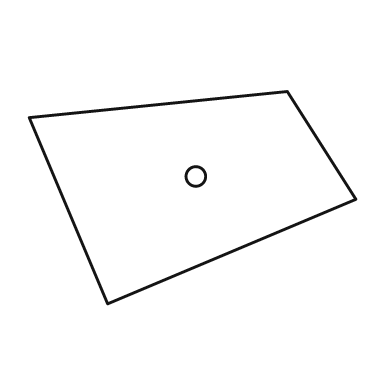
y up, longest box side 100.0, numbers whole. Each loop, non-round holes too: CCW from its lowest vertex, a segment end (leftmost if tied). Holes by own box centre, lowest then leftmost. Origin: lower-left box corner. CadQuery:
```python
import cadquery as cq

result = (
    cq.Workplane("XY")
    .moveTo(24.0, 0.0)
    .lineTo(100.0, 32.0)
    .lineTo(79.0, 65.0)
    .lineTo(0.0, 57.0)
    .close()
    .moveTo(51.0, 39.0)
    .circle(3.0)
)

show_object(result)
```